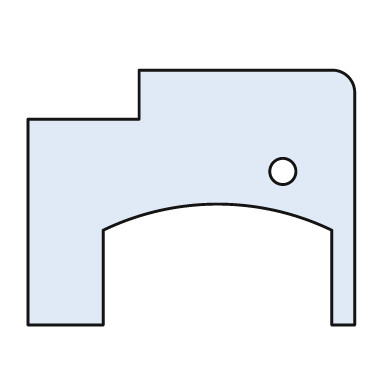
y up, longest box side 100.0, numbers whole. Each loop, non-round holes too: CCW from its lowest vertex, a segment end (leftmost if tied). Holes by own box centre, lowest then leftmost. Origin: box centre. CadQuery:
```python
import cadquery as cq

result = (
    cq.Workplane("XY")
    .moveTo(-50.0, -39.0)
    .lineTo(-27.0, -39.0)
    .lineTo(-27.0, -10.0)
    .threePointArc((8.0, -2.0), (43.0, -10.0))
    .lineTo(43.0, -39.0)
    .lineTo(50.0, -39.0)
    .lineTo(50.0, 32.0)
    .threePointArc((48.0, 37.0), (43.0, 39.0))
    .lineTo(-16.0, 39.0)
    .lineTo(-16.0, 24.0)
    .lineTo(-50.0, 24.0)
    .close()
    .moveTo(28.0, 8.0)
    .circle(4.0)
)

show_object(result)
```